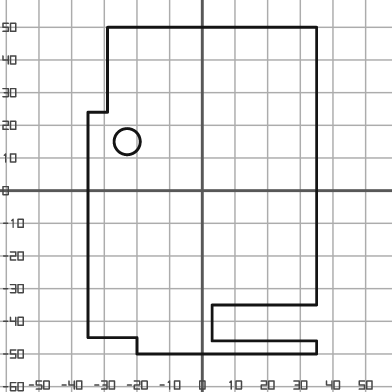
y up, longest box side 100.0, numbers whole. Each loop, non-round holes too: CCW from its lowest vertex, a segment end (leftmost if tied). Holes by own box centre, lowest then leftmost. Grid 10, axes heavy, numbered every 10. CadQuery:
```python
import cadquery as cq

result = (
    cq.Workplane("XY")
    .moveTo(-20.0, -50.0)
    .lineTo(35.0, -50.0)
    .lineTo(35.0, -46.0)
    .lineTo(3.0, -46.0)
    .lineTo(3.0, -35.0)
    .lineTo(35.0, -35.0)
    .lineTo(35.0, 50.0)
    .lineTo(-29.0, 50.0)
    .lineTo(-29.0, 24.0)
    .lineTo(-35.0, 24.0)
    .lineTo(-35.0, -45.0)
    .lineTo(-20.0, -45.0)
    .close()
    .moveTo(-23.0, 15.0)
    .circle(4.0)
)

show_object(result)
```